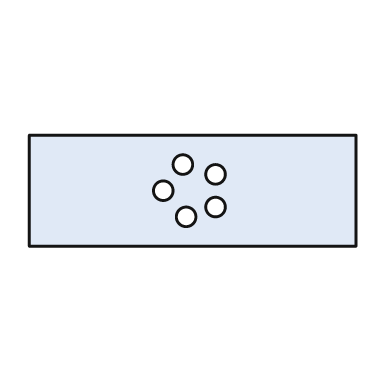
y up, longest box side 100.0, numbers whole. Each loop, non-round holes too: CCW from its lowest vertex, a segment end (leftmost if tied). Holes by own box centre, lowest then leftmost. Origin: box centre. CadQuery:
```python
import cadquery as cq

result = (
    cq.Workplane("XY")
    .moveTo(-50.0, -17.0)
    .lineTo(50.0, -17.0)
    .lineTo(50.0, 17.0)
    .lineTo(-50.0, 17.0)
    .close()
    .moveTo(-2.0, -8.0)
    .circle(3.0)
    .moveTo(7.0, -5.0)
    .circle(3.0)
    .moveTo(-9.0, 0.0)
    .circle(3.0)
    .moveTo(7.0, 5.0)
    .circle(3.0)
    .moveTo(-3.0, 8.0)
    .circle(3.0)
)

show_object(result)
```